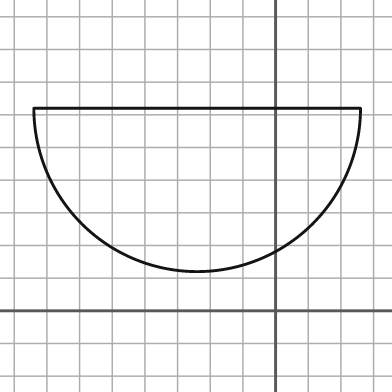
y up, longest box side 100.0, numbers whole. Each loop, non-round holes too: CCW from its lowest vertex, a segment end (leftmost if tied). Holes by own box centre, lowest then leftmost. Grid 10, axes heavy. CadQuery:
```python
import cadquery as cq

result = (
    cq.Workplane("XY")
    .moveTo(-74.0, 62.0)
    .threePointArc((-24.0, 12.0), (26.0, 62.0))
    .close()
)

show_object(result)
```